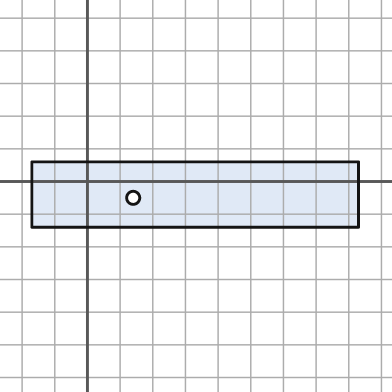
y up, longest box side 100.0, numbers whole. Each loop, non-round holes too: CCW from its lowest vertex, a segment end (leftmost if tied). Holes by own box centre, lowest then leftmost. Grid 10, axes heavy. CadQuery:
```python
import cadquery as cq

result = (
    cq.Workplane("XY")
    .moveTo(-17.0, -14.0)
    .lineTo(83.0, -14.0)
    .lineTo(83.0, 6.0)
    .lineTo(-17.0, 6.0)
    .close()
    .moveTo(14.0, -5.0)
    .circle(2.0)
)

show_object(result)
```